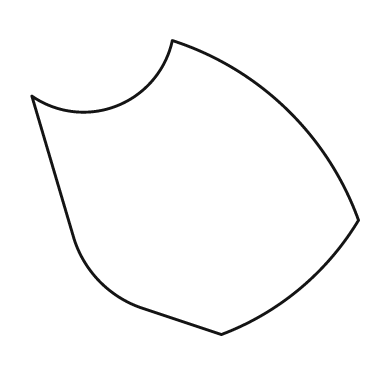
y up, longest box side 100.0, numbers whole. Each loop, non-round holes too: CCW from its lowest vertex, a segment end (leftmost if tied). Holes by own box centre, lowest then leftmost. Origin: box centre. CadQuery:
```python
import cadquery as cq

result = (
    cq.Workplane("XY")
    .moveTo(8.0, -45.0)
    .threePointArc((32.0, -31.0), (50.0, -10.0))
    .threePointArc((28.0, 24.0), (-7.0, 45.0))
    .threePointArc((-24.0, 25.0), (-50.0, 28.0))
    .lineTo(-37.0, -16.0)
    .threePointArc((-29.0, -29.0), (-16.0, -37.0))
    .close()
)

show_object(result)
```